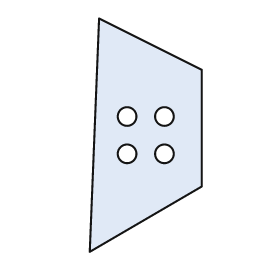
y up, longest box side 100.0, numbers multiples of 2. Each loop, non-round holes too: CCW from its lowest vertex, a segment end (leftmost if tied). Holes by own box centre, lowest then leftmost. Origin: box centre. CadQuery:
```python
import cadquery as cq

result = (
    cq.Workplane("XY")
    .moveTo(-24.0, -50.0)
    .lineTo(24.0, -22.0)
    .lineTo(24.0, 28.0)
    .lineTo(-20.0, 50.0)
    .close()
    .moveTo(-8.0, -8.0)
    .circle(4.0)
    .moveTo(8.0, -8.0)
    .circle(4.0)
    .moveTo(-8.0, 8.0)
    .circle(4.0)
    .moveTo(8.0, 8.0)
    .circle(4.0)
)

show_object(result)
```